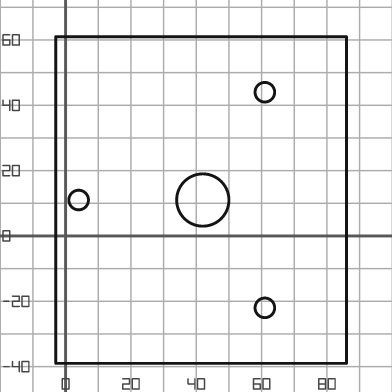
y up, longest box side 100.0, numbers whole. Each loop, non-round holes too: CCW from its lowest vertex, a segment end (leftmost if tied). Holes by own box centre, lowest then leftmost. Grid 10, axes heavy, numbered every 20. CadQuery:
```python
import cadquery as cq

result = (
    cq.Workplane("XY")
    .moveTo(-3.0, -39.0)
    .lineTo(86.0, -39.0)
    .lineTo(86.0, 61.0)
    .lineTo(-3.0, 61.0)
    .close()
    .moveTo(61.0, -22.0)
    .circle(3.0)
    .moveTo(4.0, 11.0)
    .circle(3.0)
    .moveTo(42.0, 11.0)
    .circle(8.0)
    .moveTo(61.0, 44.0)
    .circle(3.0)
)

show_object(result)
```